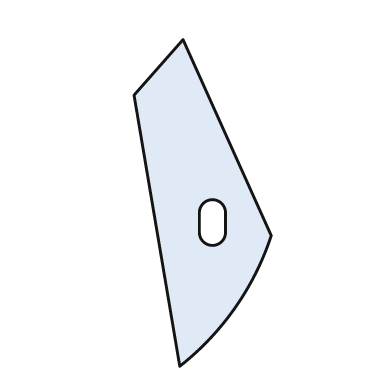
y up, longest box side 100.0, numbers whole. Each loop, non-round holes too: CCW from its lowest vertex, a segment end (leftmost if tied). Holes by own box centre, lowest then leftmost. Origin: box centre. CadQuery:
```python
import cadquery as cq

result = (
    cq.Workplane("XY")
    .moveTo(-7.0, -50.0)
    .threePointArc((10.0, -32.0), (21.0, -10.0))
    .lineTo(-6.0, 50.0)
    .lineTo(-21.0, 33.0)
    .close()
    .moveTo(-1.0, -9.0)
    .threePointArc((3.0, -13.0), (7.0, -9.0))
    .lineTo(7.0, -3.0)
    .threePointArc((3.0, 1.0), (-1.0, -3.0))
    .close()
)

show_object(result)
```